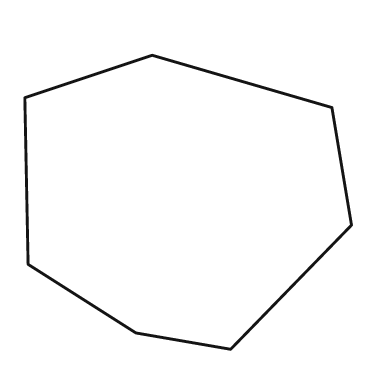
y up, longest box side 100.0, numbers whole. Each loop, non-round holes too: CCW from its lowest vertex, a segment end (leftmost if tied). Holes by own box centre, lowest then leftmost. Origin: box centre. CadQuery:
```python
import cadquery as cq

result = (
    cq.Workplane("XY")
    .moveTo(13.0, -45.0)
    .lineTo(50.0, -7.0)
    .lineTo(44.0, 29.0)
    .lineTo(-11.0, 45.0)
    .lineTo(-50.0, 32.0)
    .lineTo(-49.0, -19.0)
    .lineTo(-16.0, -40.0)
    .close()
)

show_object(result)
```